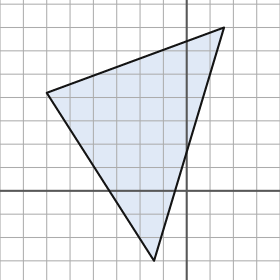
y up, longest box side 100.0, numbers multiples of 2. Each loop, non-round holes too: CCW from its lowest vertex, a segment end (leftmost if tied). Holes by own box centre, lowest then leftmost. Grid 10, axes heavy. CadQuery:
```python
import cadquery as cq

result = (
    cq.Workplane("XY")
    .moveTo(-14.0, -30.0)
    .lineTo(16.0, 70.0)
    .lineTo(-60.0, 42.0)
    .close()
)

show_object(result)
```